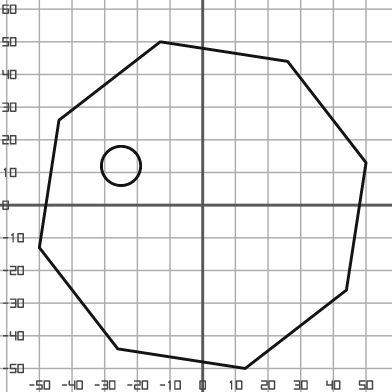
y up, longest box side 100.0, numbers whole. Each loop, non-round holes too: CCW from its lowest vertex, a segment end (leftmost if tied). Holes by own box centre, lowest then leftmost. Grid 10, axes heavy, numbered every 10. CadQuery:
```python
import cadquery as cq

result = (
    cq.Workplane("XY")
    .moveTo(13.0, -50.0)
    .lineTo(44.0, -26.0)
    .lineTo(50.0, 13.0)
    .lineTo(26.0, 44.0)
    .lineTo(-13.0, 50.0)
    .lineTo(-44.0, 26.0)
    .lineTo(-50.0, -13.0)
    .lineTo(-26.0, -44.0)
    .close()
    .moveTo(-25.0, 12.0)
    .circle(6.0)
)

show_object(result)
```